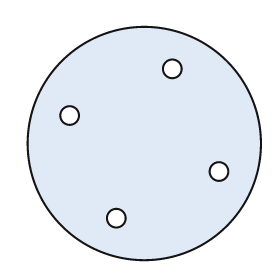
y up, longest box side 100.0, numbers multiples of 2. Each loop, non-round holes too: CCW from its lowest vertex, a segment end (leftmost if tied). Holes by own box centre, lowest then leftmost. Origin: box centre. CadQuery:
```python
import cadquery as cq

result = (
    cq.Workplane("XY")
    .moveTo(0.0, 0.0)
    .circle(50.0)
    .moveTo(-12.0, -32.0)
    .circle(4.0)
    .moveTo(32.0, -12.0)
    .circle(4.0)
    .moveTo(-32.0, 12.0)
    .circle(4.0)
    .moveTo(12.0, 32.0)
    .circle(4.0)
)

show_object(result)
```